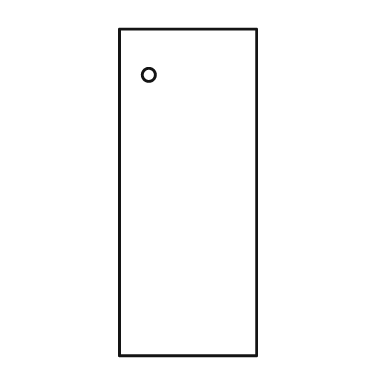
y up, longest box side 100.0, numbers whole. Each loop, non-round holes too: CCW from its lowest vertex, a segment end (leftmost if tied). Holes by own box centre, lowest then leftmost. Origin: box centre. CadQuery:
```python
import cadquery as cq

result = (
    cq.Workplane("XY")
    .moveTo(-21.0, -50.0)
    .lineTo(21.0, -50.0)
    .lineTo(21.0, 50.0)
    .lineTo(-21.0, 50.0)
    .close()
    .moveTo(-12.0, 36.0)
    .circle(2.0)
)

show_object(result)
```